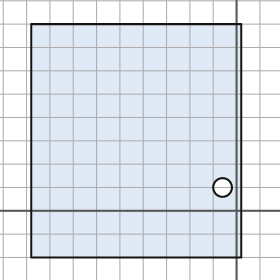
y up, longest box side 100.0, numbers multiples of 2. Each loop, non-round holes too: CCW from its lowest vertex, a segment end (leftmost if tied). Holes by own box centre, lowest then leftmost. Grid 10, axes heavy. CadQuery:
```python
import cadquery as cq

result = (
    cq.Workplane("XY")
    .moveTo(-88.0, -20.0)
    .lineTo(2.0, -20.0)
    .lineTo(2.0, 80.0)
    .lineTo(-88.0, 80.0)
    .close()
    .moveTo(-6.0, 10.0)
    .circle(4.0)
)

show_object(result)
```